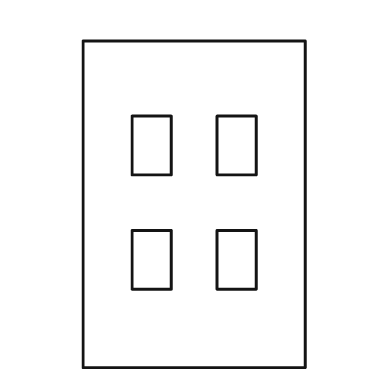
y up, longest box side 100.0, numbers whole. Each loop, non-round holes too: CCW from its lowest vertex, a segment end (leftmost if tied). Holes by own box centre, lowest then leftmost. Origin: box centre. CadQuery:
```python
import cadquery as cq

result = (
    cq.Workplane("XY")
    .moveTo(-34.0, -50.0)
    .lineTo(34.0, -50.0)
    .lineTo(34.0, 50.0)
    .lineTo(-34.0, 50.0)
    .close()
    .moveTo(-19.0, -26.0)
    .lineTo(-7.0, -26.0)
    .lineTo(-7.0, -8.0)
    .lineTo(-19.0, -8.0)
    .close()
    .moveTo(7.0, -26.0)
    .lineTo(19.0, -26.0)
    .lineTo(19.0, -8.0)
    .lineTo(7.0, -8.0)
    .close()
    .moveTo(-19.0, 9.0)
    .lineTo(-7.0, 9.0)
    .lineTo(-7.0, 27.0)
    .lineTo(-19.0, 27.0)
    .close()
    .moveTo(7.0, 9.0)
    .lineTo(19.0, 9.0)
    .lineTo(19.0, 27.0)
    .lineTo(7.0, 27.0)
    .close()
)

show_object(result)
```